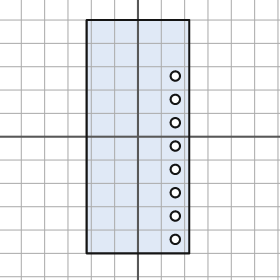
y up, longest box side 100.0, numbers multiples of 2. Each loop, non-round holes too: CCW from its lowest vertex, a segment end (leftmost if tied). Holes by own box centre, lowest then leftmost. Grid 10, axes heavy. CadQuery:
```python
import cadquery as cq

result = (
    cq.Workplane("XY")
    .moveTo(-22.0, -50.0)
    .lineTo(22.0, -50.0)
    .lineTo(22.0, 50.0)
    .lineTo(-22.0, 50.0)
    .close()
    .moveTo(16.0, -44.0)
    .circle(2.0)
    .moveTo(16.0, -34.0)
    .circle(2.0)
    .moveTo(16.0, -24.0)
    .circle(2.0)
    .moveTo(16.0, -14.0)
    .circle(2.0)
    .moveTo(16.0, -4.0)
    .circle(2.0)
    .moveTo(16.0, 6.0)
    .circle(2.0)
    .moveTo(16.0, 16.0)
    .circle(2.0)
    .moveTo(16.0, 26.0)
    .circle(2.0)
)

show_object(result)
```